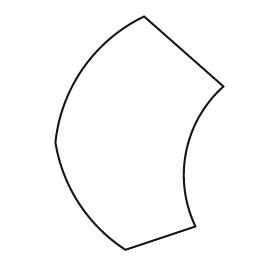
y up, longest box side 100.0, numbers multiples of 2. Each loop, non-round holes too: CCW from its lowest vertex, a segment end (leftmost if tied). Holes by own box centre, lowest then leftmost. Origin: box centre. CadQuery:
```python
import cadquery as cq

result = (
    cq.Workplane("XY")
    .moveTo(-6.0, -50.0)
    .lineTo(24.0, -40.0)
    .threePointArc((20.0, -8.0), (36.0, 20.0))
    .lineTo(2.0, 50.0)
    .threePointArc((-24.0, 28.0), (-36.0, -4.0))
    .threePointArc((-26.0, -30.0), (-6.0, -50.0))
    .close()
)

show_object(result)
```